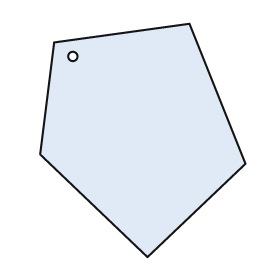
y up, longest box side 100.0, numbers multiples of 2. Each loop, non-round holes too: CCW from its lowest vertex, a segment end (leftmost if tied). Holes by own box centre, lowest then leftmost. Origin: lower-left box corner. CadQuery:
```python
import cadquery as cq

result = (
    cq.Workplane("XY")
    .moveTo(46.0, 0.0)
    .lineTo(88.0, 40.0)
    .lineTo(64.0, 100.0)
    .lineTo(6.0, 92.0)
    .lineTo(0.0, 44.0)
    .close()
    .moveTo(14.0, 86.0)
    .circle(2.0)
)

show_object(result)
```